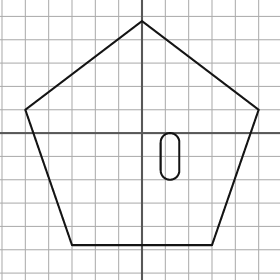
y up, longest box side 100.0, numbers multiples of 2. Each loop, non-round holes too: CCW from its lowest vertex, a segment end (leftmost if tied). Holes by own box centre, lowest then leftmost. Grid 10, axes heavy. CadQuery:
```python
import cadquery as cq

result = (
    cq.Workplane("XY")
    .moveTo(-30.0, -48.0)
    .lineTo(30.0, -48.0)
    .lineTo(50.0, 10.0)
    .lineTo(0.0, 48.0)
    .lineTo(-50.0, 10.0)
    .close()
    .moveTo(8.0, -16.0)
    .threePointArc((12.0, -20.0), (16.0, -16.0))
    .lineTo(16.0, -4.0)
    .threePointArc((12.0, 0.0), (8.0, -4.0))
    .close()
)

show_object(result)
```